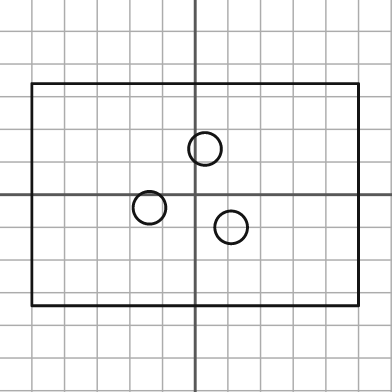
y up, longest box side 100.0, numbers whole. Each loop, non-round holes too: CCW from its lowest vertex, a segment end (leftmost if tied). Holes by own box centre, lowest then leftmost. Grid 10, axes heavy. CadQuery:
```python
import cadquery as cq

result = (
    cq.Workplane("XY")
    .moveTo(-50.0, -34.0)
    .lineTo(50.0, -34.0)
    .lineTo(50.0, 34.0)
    .lineTo(-50.0, 34.0)
    .close()
    .moveTo(11.0, -10.0)
    .circle(5.0)
    .moveTo(-14.0, -4.0)
    .circle(5.0)
    .moveTo(3.0, 14.0)
    .circle(5.0)
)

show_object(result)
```